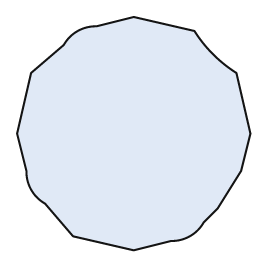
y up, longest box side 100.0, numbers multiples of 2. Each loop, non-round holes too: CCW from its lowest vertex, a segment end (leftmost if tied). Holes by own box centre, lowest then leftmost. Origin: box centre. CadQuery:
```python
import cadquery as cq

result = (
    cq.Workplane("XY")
    .moveTo(0.0, -50.0)
    .lineTo(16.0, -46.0)
    .threePointArc((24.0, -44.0), (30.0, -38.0))
    .lineTo(36.0, -32.0)
    .lineTo(46.0, -16.0)
    .lineTo(50.0, 0.0)
    .lineTo(44.0, 26.0)
    .threePointArc((34.0, 34.0), (26.0, 44.0))
    .lineTo(0.0, 50.0)
    .lineTo(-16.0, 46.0)
    .threePointArc((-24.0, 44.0), (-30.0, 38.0))
    .lineTo(-44.0, 26.0)
    .lineTo(-50.0, 0.0)
    .lineTo(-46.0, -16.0)
    .threePointArc((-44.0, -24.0), (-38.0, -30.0))
    .lineTo(-26.0, -44.0)
    .close()
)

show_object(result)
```